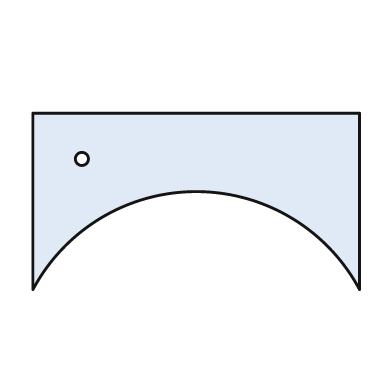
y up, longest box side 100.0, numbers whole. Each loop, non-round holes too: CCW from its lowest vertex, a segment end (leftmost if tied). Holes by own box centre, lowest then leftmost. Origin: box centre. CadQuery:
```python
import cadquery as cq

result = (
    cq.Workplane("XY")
    .moveTo(-50.0, -27.0)
    .threePointArc((0.0, 3.0), (50.0, -27.0))
    .lineTo(50.0, 27.0)
    .lineTo(-50.0, 27.0)
    .close()
    .moveTo(-35.0, 13.0)
    .circle(2.0)
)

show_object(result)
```